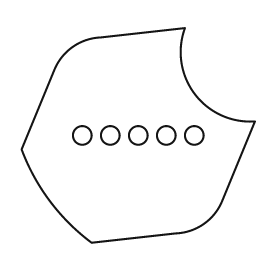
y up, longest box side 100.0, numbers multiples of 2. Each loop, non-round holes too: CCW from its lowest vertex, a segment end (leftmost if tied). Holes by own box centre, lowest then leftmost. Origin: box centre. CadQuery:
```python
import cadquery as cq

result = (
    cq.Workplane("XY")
    .moveTo(-20.0, -46.0)
    .lineTo(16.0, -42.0)
    .threePointArc((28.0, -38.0), (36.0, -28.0))
    .lineTo(50.0, 6.0)
    .threePointArc((24.0, 18.0), (20.0, 46.0))
    .lineTo(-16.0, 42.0)
    .threePointArc((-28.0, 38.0), (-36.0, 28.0))
    .lineTo(-50.0, -6.0)
    .threePointArc((-38.0, -28.0), (-20.0, -46.0))
    .close()
    .moveTo(-24.0, 0.0)
    .circle(4.0)
    .moveTo(-12.0, 0.0)
    .circle(4.0)
    .moveTo(0.0, 0.0)
    .circle(4.0)
    .moveTo(12.0, 0.0)
    .circle(4.0)
    .moveTo(24.0, 0.0)
    .circle(4.0)
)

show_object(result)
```